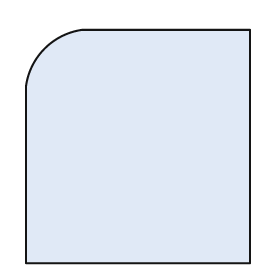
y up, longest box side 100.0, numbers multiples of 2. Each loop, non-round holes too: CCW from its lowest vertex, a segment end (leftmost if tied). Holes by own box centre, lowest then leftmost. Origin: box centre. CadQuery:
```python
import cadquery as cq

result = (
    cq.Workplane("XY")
    .moveTo(-48.0, -50.0)
    .lineTo(48.0, -50.0)
    .lineTo(48.0, 50.0)
    .lineTo(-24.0, 50.0)
    .threePointArc((-40.0, 42.0), (-48.0, 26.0))
    .close()
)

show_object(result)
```